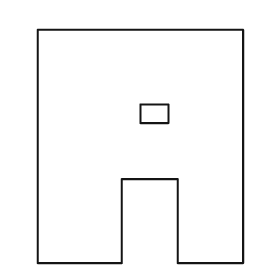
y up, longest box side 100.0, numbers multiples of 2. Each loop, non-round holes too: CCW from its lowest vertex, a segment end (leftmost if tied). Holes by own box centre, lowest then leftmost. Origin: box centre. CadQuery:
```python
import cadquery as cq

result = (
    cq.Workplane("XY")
    .moveTo(-44.0, -50.0)
    .lineTo(-8.0, -50.0)
    .lineTo(-8.0, -14.0)
    .lineTo(16.0, -14.0)
    .lineTo(16.0, -50.0)
    .lineTo(44.0, -50.0)
    .lineTo(44.0, 50.0)
    .lineTo(-44.0, 50.0)
    .close()
    .moveTo(0.0, 10.0)
    .lineTo(12.0, 10.0)
    .lineTo(12.0, 18.0)
    .lineTo(0.0, 18.0)
    .close()
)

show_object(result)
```